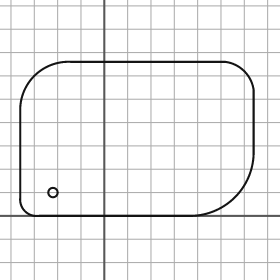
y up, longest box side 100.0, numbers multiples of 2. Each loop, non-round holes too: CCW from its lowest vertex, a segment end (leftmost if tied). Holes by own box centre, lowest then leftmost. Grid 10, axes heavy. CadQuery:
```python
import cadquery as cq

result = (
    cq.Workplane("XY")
    .moveTo(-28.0, 0.0)
    .lineTo(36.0, 0.0)
    .threePointArc((56.0, 8.0), (64.0, 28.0))
    .lineTo(64.0, 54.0)
    .threePointArc((60.0, 62.0), (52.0, 66.0))
    .lineTo(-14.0, 66.0)
    .threePointArc((-30.0, 60.0), (-36.0, 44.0))
    .lineTo(-36.0, 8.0)
    .threePointArc((-34.0, 2.0), (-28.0, 0.0))
    .close()
    .moveTo(-22.0, 10.0)
    .circle(2.0)
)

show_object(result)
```